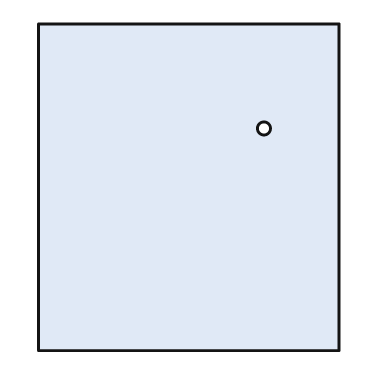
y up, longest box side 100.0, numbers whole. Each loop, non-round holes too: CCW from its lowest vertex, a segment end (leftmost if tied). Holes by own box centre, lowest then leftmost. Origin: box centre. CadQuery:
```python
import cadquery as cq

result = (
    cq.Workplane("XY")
    .moveTo(-46.0, -50.0)
    .lineTo(46.0, -50.0)
    .lineTo(46.0, 50.0)
    .lineTo(-46.0, 50.0)
    .close()
    .moveTo(23.0, 18.0)
    .circle(2.0)
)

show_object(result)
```